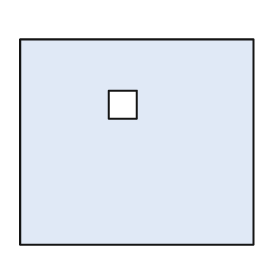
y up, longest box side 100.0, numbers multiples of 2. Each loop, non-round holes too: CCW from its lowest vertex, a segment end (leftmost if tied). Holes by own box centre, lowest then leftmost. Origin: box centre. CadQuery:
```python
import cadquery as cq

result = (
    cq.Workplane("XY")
    .moveTo(-50.0, -44.0)
    .lineTo(50.0, -44.0)
    .lineTo(50.0, 44.0)
    .lineTo(-50.0, 44.0)
    .close()
    .moveTo(-12.0, 10.0)
    .lineTo(0.0, 10.0)
    .lineTo(0.0, 22.0)
    .lineTo(-12.0, 22.0)
    .close()
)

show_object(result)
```